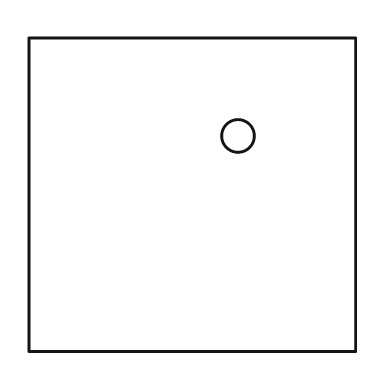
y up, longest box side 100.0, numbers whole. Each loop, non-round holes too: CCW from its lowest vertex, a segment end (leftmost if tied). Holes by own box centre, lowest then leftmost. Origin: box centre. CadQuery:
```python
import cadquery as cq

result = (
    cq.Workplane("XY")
    .moveTo(-50.0, -48.0)
    .lineTo(50.0, -48.0)
    .lineTo(50.0, 48.0)
    .lineTo(-50.0, 48.0)
    .close()
    .moveTo(14.0, 18.0)
    .circle(5.0)
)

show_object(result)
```